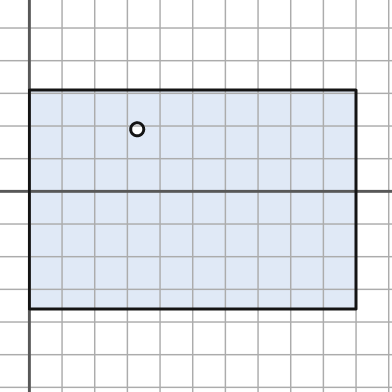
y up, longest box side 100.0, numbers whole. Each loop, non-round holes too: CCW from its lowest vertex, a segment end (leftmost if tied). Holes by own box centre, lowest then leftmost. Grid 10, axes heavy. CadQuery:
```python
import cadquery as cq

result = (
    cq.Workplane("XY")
    .moveTo(0.0, -36.0)
    .lineTo(100.0, -36.0)
    .lineTo(100.0, 31.0)
    .lineTo(0.0, 31.0)
    .close()
    .moveTo(33.0, 19.0)
    .circle(2.0)
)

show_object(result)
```